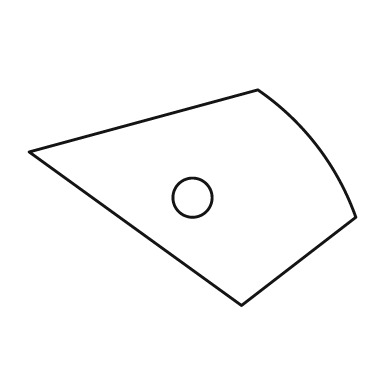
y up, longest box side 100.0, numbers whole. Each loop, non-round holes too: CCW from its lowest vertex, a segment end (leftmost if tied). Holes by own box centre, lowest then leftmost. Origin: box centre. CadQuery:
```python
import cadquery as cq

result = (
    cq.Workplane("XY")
    .moveTo(15.0, -33.0)
    .lineTo(50.0, -6.0)
    .threePointArc((38.0, 16.0), (20.0, 33.0))
    .lineTo(-50.0, 14.0)
    .close()
    .moveTo(0.0, 0.0)
    .circle(6.0)
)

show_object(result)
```